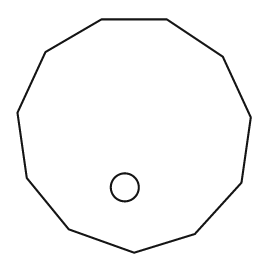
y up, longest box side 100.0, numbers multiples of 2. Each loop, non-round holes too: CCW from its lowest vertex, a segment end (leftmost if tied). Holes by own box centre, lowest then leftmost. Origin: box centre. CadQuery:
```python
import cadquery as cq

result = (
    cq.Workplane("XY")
    .moveTo(0.0, -50.0)
    .lineTo(26.0, -42.0)
    .lineTo(46.0, -20.0)
    .lineTo(50.0, 8.0)
    .lineTo(38.0, 34.0)
    .lineTo(14.0, 50.0)
    .lineTo(-14.0, 50.0)
    .lineTo(-38.0, 36.0)
    .lineTo(-50.0, 10.0)
    .lineTo(-46.0, -18.0)
    .lineTo(-28.0, -40.0)
    .close()
    .moveTo(-4.0, -22.0)
    .circle(6.0)
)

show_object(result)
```